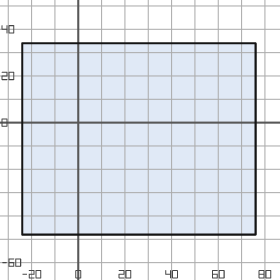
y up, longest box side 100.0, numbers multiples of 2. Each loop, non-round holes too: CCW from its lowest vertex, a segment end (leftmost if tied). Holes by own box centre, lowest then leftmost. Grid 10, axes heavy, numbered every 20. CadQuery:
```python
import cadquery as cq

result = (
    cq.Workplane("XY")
    .moveTo(-24.0, -48.0)
    .lineTo(76.0, -48.0)
    .lineTo(76.0, 34.0)
    .lineTo(-24.0, 34.0)
    .close()
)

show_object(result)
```